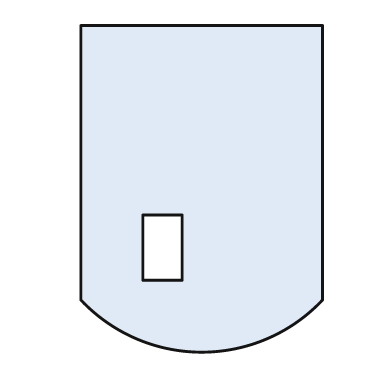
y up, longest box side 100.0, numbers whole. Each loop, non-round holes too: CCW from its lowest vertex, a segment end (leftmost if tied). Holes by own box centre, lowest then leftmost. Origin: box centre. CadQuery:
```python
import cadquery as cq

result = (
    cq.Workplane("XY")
    .moveTo(-37.0, -34.0)
    .threePointArc((0.0, -50.0), (37.0, -34.0))
    .lineTo(37.0, 50.0)
    .lineTo(-37.0, 50.0)
    .close()
    .moveTo(-18.0, -28.0)
    .lineTo(-6.0, -28.0)
    .lineTo(-6.0, -8.0)
    .lineTo(-18.0, -8.0)
    .close()
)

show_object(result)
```